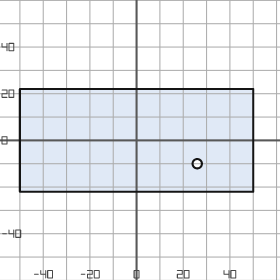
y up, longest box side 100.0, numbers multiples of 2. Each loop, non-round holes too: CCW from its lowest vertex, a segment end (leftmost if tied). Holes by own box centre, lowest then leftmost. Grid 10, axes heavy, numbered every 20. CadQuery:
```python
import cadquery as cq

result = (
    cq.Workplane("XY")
    .moveTo(-50.0, -22.0)
    .lineTo(50.0, -22.0)
    .lineTo(50.0, 22.0)
    .lineTo(-50.0, 22.0)
    .close()
    .moveTo(26.0, -10.0)
    .circle(2.0)
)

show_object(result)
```